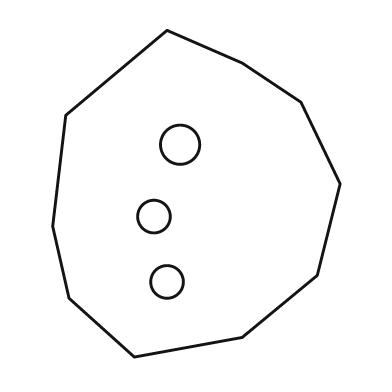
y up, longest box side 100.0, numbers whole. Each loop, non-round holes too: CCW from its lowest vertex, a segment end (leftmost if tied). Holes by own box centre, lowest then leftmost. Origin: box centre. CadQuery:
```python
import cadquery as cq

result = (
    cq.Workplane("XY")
    .moveTo(-19.0, -50.0)
    .lineTo(14.0, -44.0)
    .lineTo(37.0, -25.0)
    .lineTo(44.0, 3.0)
    .lineTo(32.0, 28.0)
    .lineTo(14.0, 40.0)
    .lineTo(-9.0, 50.0)
    .lineTo(-40.0, 24.0)
    .lineTo(-44.0, -10.0)
    .lineTo(-39.0, -32.0)
    .close()
    .moveTo(-9.0, -27.0)
    .circle(5.0)
    .moveTo(-13.0, -7.0)
    .circle(5.0)
    .moveTo(-5.0, 15.0)
    .circle(6.0)
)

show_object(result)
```